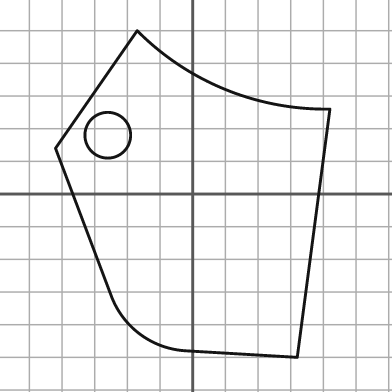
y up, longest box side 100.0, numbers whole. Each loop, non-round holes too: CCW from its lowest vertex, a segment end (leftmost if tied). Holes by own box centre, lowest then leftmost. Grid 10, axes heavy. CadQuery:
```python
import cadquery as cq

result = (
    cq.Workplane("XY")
    .moveTo(32.0, -50.0)
    .lineTo(42.0, 26.0)
    .threePointArc((10.0, 32.0), (-17.0, 50.0))
    .lineTo(-42.0, 14.0)
    .lineTo(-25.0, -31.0)
    .threePointArc((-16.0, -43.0), (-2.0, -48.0))
    .close()
    .moveTo(-26.0, 18.0)
    .circle(7.0)
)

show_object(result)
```